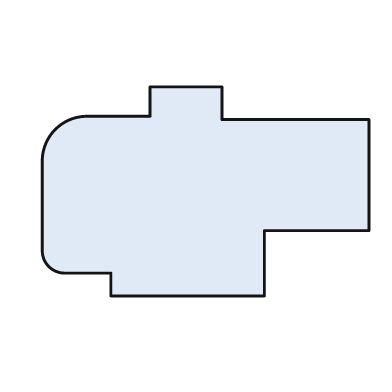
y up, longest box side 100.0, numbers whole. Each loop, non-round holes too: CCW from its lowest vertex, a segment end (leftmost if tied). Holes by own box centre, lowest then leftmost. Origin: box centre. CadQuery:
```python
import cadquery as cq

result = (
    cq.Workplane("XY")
    .moveTo(-29.0, -32.0)
    .lineTo(18.0, -32.0)
    .lineTo(18.0, -12.0)
    .lineTo(50.0, -12.0)
    .lineTo(50.0, 22.0)
    .lineTo(5.0, 22.0)
    .lineTo(5.0, 32.0)
    .lineTo(-17.0, 32.0)
    .lineTo(-17.0, 23.0)
    .lineTo(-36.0, 23.0)
    .threePointArc((-46.0, 19.0), (-50.0, 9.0))
    .lineTo(-50.0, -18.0)
    .threePointArc((-48.0, -23.0), (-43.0, -25.0))
    .lineTo(-29.0, -25.0)
    .close()
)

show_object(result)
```